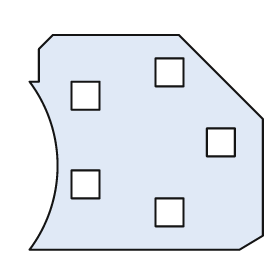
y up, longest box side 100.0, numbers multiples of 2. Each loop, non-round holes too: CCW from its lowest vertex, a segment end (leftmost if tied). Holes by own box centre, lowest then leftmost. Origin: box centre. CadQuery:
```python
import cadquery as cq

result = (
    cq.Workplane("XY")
    .moveTo(-50.0, -46.0)
    .lineTo(40.0, -46.0)
    .lineTo(50.0, -40.0)
    .lineTo(50.0, 10.0)
    .lineTo(14.0, 46.0)
    .lineTo(-40.0, 46.0)
    .lineTo(-46.0, 40.0)
    .lineTo(-46.0, 26.0)
    .lineTo(-50.0, 26.0)
    .threePointArc((-38.0, -10.0), (-50.0, -46.0))
    .close()
    .moveTo(4.0, -36.0)
    .lineTo(16.0, -36.0)
    .lineTo(16.0, -24.0)
    .lineTo(4.0, -24.0)
    .close()
    .moveTo(-32.0, -24.0)
    .lineTo(-20.0, -24.0)
    .lineTo(-20.0, -12.0)
    .lineTo(-32.0, -12.0)
    .close()
    .moveTo(26.0, -6.0)
    .lineTo(38.0, -6.0)
    .lineTo(38.0, 6.0)
    .lineTo(26.0, 6.0)
    .close()
    .moveTo(-32.0, 14.0)
    .lineTo(-20.0, 14.0)
    .lineTo(-20.0, 26.0)
    .lineTo(-32.0, 26.0)
    .close()
    .moveTo(4.0, 24.0)
    .lineTo(16.0, 24.0)
    .lineTo(16.0, 36.0)
    .lineTo(4.0, 36.0)
    .close()
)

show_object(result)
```